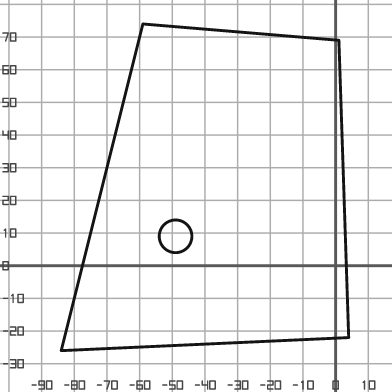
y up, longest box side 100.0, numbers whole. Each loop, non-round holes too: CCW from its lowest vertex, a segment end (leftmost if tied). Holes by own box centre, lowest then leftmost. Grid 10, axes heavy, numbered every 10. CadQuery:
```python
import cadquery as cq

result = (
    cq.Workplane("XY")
    .moveTo(-84.0, -26.0)
    .lineTo(4.0, -22.0)
    .lineTo(1.0, 69.0)
    .lineTo(-59.0, 74.0)
    .close()
    .moveTo(-49.0, 9.0)
    .circle(5.0)
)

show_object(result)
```